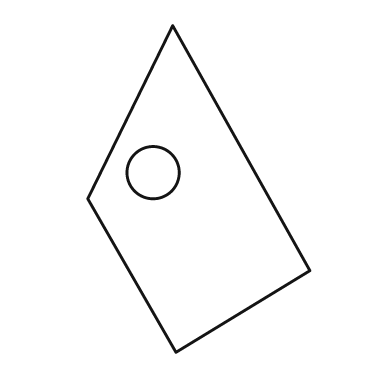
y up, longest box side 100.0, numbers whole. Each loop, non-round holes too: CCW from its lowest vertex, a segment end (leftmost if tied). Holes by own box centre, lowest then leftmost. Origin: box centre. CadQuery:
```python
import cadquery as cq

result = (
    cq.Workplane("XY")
    .moveTo(-7.0, -50.0)
    .lineTo(34.0, -25.0)
    .lineTo(-8.0, 50.0)
    .lineTo(-34.0, -3.0)
    .close()
    .moveTo(-14.0, 5.0)
    .circle(8.0)
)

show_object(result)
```